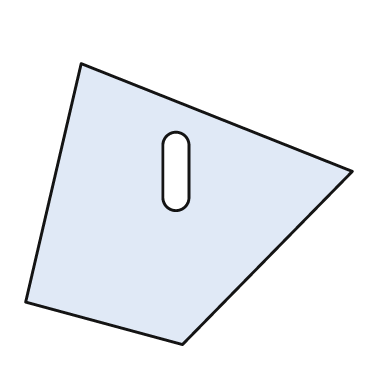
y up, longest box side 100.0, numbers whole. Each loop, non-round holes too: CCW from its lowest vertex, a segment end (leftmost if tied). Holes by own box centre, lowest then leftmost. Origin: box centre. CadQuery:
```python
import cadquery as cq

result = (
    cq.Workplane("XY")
    .moveTo(-2.0, -43.0)
    .lineTo(50.0, 10.0)
    .lineTo(-33.0, 43.0)
    .lineTo(-50.0, -30.0)
    .close()
    .moveTo(-8.0, 2.0)
    .threePointArc((-4.0, -2.0), (0.0, 2.0))
    .lineTo(0.0, 18.0)
    .threePointArc((-4.0, 22.0), (-8.0, 18.0))
    .close()
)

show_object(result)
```